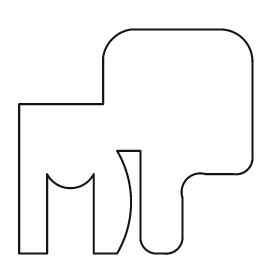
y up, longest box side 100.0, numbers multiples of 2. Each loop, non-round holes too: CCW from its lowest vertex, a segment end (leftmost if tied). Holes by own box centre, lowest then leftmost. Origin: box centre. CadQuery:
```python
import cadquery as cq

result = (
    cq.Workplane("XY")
    .moveTo(-50.0, -48.0)
    .lineTo(-38.0, -48.0)
    .lineTo(-38.0, -14.0)
    .threePointArc((-28.0, -20.0), (-18.0, -14.0))
    .lineTo(-18.0, -48.0)
    .lineTo(-8.0, -48.0)
    .threePointArc((-2.0, -26.0), (-8.0, -4.0))
    .lineTo(2.0, -4.0)
    .lineTo(2.0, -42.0)
    .threePointArc((4.0, -46.0), (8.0, -48.0))
    .lineTo(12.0, -48.0)
    .threePointArc((18.0, -46.0), (20.0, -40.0))
    .lineTo(20.0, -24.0)
    .threePointArc((22.0, -16.0), (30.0, -14.0))
    .lineTo(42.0, -14.0)
    .threePointArc((48.0, -12.0), (50.0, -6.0))
    .lineTo(50.0, 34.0)
    .threePointArc((46.0, 44.0), (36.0, 48.0))
    .lineTo(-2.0, 48.0)
    .threePointArc((-10.0, 44.0), (-14.0, 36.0))
    .lineTo(-14.0, 16.0)
    .lineTo(-50.0, 16.0)
    .close()
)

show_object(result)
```